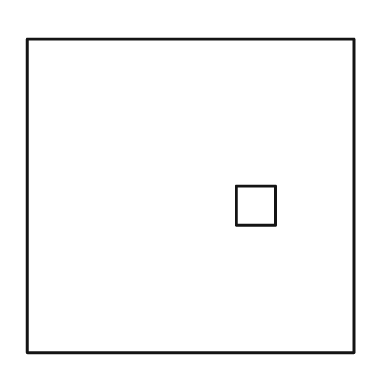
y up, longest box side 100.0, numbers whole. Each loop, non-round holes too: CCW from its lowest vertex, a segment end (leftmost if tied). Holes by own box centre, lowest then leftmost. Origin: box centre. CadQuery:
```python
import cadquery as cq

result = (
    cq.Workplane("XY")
    .moveTo(-50.0, -48.0)
    .lineTo(50.0, -48.0)
    .lineTo(50.0, 48.0)
    .lineTo(-50.0, 48.0)
    .close()
    .moveTo(14.0, -9.0)
    .lineTo(26.0, -9.0)
    .lineTo(26.0, 3.0)
    .lineTo(14.0, 3.0)
    .close()
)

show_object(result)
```